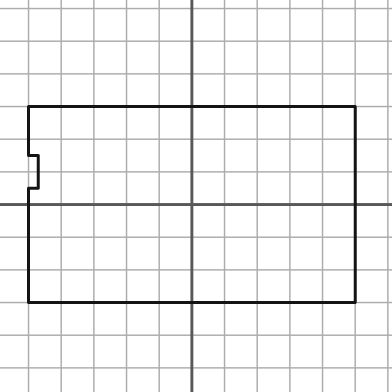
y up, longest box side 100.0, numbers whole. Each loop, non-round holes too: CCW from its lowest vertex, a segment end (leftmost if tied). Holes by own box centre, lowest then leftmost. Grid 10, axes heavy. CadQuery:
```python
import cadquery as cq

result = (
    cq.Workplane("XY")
    .moveTo(-50.0, -30.0)
    .lineTo(50.0, -30.0)
    .lineTo(50.0, 30.0)
    .lineTo(-50.0, 30.0)
    .lineTo(-50.0, 15.0)
    .lineTo(-47.0, 15.0)
    .lineTo(-47.0, 5.0)
    .lineTo(-50.0, 5.0)
    .close()
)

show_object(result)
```